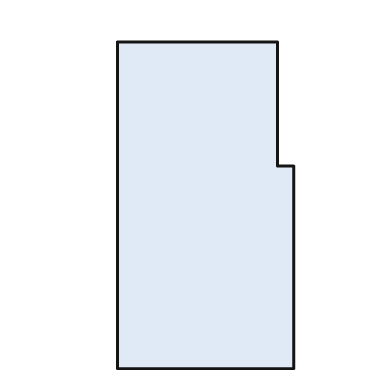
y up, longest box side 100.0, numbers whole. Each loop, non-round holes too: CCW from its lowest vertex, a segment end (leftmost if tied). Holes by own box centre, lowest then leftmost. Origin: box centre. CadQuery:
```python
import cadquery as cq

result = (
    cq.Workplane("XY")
    .moveTo(-27.0, -50.0)
    .lineTo(27.0, -50.0)
    .lineTo(27.0, 12.0)
    .lineTo(22.0, 12.0)
    .lineTo(22.0, 50.0)
    .lineTo(-27.0, 50.0)
    .close()
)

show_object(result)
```